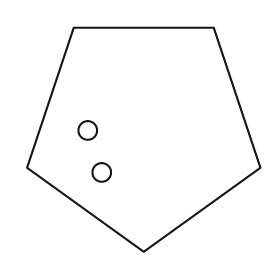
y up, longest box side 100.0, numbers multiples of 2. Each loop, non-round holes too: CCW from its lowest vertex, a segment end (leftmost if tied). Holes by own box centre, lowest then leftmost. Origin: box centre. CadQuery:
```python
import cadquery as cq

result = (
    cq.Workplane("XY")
    .moveTo(0.0, -48.0)
    .lineTo(50.0, -12.0)
    .lineTo(30.0, 48.0)
    .lineTo(-30.0, 48.0)
    .lineTo(-50.0, -12.0)
    .close()
    .moveTo(-18.0, -14.0)
    .circle(4.0)
    .moveTo(-24.0, 4.0)
    .circle(4.0)
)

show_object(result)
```